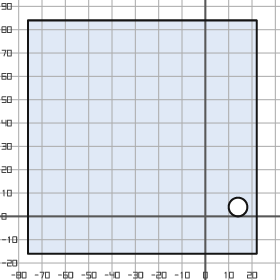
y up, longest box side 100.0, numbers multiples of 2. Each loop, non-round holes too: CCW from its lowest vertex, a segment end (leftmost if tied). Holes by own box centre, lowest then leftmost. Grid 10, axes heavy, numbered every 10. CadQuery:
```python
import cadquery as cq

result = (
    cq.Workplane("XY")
    .moveTo(-76.0, -16.0)
    .lineTo(22.0, -16.0)
    .lineTo(22.0, 84.0)
    .lineTo(-76.0, 84.0)
    .close()
    .moveTo(14.0, 4.0)
    .circle(4.0)
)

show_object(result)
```